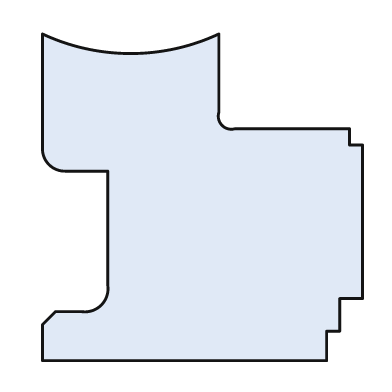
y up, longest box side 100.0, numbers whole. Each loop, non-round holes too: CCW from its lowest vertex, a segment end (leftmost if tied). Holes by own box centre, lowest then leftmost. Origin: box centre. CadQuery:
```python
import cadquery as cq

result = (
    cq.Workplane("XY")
    .moveTo(-49.0, -50.0)
    .lineTo(38.0, -50.0)
    .lineTo(38.0, -41.0)
    .lineTo(42.0, -41.0)
    .lineTo(42.0, -31.0)
    .lineTo(49.0, -31.0)
    .lineTo(49.0, 16.0)
    .lineTo(45.0, 16.0)
    .lineTo(45.0, 21.0)
    .lineTo(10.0, 21.0)
    .threePointArc((6.0, 22.0), (5.0, 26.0))
    .lineTo(5.0, 50.0)
    .threePointArc((-22.0, 44.0), (-49.0, 50.0))
    .lineTo(-49.0, 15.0)
    .threePointArc((-47.0, 10.0), (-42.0, 8.0))
    .lineTo(-29.0, 8.0)
    .lineTo(-29.0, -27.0)
    .threePointArc((-31.0, -33.0), (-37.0, -35.0))
    .lineTo(-45.0, -35.0)
    .lineTo(-49.0, -39.0)
    .close()
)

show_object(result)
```